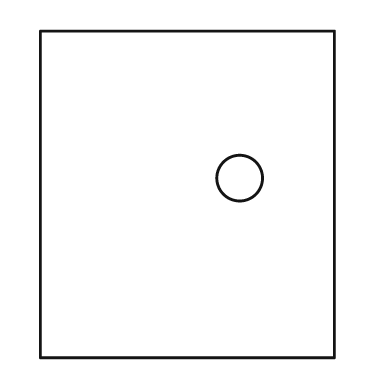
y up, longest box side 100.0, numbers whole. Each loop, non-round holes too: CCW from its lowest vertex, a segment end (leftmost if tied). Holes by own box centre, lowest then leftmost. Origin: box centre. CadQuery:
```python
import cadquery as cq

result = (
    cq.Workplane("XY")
    .moveTo(-45.0, -50.0)
    .lineTo(45.0, -50.0)
    .lineTo(45.0, 50.0)
    .lineTo(-45.0, 50.0)
    .close()
    .moveTo(16.0, 5.0)
    .circle(7.0)
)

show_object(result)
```